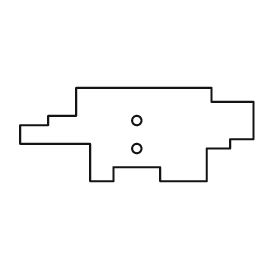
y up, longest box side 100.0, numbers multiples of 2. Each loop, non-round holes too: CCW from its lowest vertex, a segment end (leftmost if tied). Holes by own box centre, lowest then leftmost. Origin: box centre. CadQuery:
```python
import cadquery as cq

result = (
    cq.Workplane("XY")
    .moveTo(-20.0, -20.0)
    .lineTo(-10.0, -20.0)
    .lineTo(-10.0, -14.0)
    .lineTo(10.0, -14.0)
    .lineTo(10.0, -20.0)
    .lineTo(30.0, -20.0)
    .lineTo(30.0, -6.0)
    .lineTo(40.0, -6.0)
    .lineTo(40.0, -2.0)
    .lineTo(50.0, -2.0)
    .lineTo(50.0, 14.0)
    .lineTo(32.0, 14.0)
    .lineTo(32.0, 20.0)
    .lineTo(-26.0, 20.0)
    .lineTo(-26.0, 8.0)
    .lineTo(-38.0, 8.0)
    .lineTo(-38.0, 4.0)
    .lineTo(-50.0, 4.0)
    .lineTo(-50.0, -4.0)
    .lineTo(-20.0, -4.0)
    .close()
    .moveTo(0.0, -6.0)
    .circle(2.0)
    .moveTo(0.0, 6.0)
    .circle(2.0)
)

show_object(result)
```